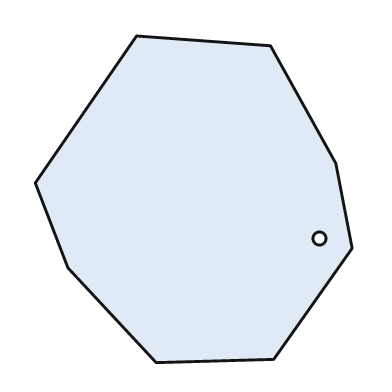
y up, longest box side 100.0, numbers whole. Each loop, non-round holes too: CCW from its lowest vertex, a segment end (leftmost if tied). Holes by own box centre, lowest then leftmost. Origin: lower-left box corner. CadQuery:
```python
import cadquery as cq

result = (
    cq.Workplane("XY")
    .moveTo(37.0, 0.0)
    .lineTo(73.0, 1.0)
    .lineTo(97.0, 35.0)
    .lineTo(92.0, 61.0)
    .lineTo(72.0, 97.0)
    .lineTo(31.0, 100.0)
    .lineTo(0.0, 55.0)
    .lineTo(10.0, 29.0)
    .close()
    .moveTo(87.0, 38.0)
    .circle(2.0)
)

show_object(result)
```